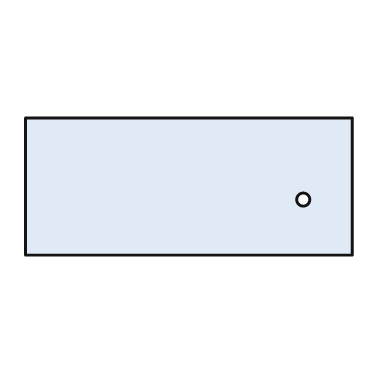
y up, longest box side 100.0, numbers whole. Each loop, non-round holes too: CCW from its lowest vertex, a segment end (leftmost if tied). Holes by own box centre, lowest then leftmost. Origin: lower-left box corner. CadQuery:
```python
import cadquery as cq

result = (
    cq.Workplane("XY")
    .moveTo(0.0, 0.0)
    .lineTo(100.0, 0.0)
    .lineTo(100.0, 42.0)
    .lineTo(0.0, 42.0)
    .close()
    .moveTo(85.0, 17.0)
    .circle(2.0)
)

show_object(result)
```